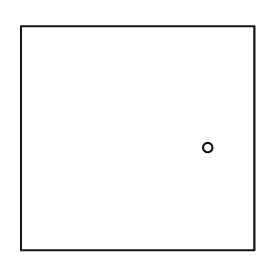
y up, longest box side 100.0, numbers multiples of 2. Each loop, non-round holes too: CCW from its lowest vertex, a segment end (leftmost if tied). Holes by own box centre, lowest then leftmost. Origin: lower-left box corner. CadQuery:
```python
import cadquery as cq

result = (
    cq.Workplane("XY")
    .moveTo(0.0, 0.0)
    .lineTo(100.0, 0.0)
    .lineTo(100.0, 96.0)
    .lineTo(0.0, 96.0)
    .close()
    .moveTo(80.0, 44.0)
    .circle(2.0)
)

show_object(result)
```